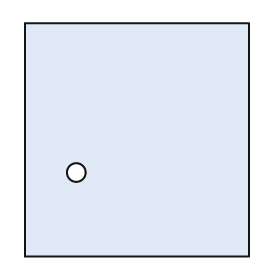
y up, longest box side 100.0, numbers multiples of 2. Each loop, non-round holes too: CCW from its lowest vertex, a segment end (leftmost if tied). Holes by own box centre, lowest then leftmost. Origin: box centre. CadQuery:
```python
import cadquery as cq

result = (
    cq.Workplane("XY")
    .moveTo(-48.0, -50.0)
    .lineTo(48.0, -50.0)
    .lineTo(48.0, 50.0)
    .lineTo(-48.0, 50.0)
    .close()
    .moveTo(-26.0, -14.0)
    .circle(4.0)
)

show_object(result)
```